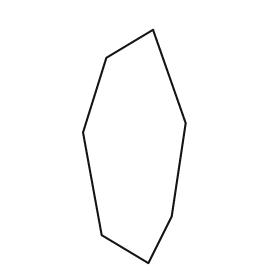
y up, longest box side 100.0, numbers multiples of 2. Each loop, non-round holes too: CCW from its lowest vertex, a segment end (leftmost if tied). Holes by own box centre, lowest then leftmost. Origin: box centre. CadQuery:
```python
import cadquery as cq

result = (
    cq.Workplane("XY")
    .moveTo(6.0, -50.0)
    .lineTo(16.0, -30.0)
    .lineTo(22.0, 10.0)
    .lineTo(8.0, 50.0)
    .lineTo(-12.0, 38.0)
    .lineTo(-22.0, 6.0)
    .lineTo(-14.0, -38.0)
    .close()
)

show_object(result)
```